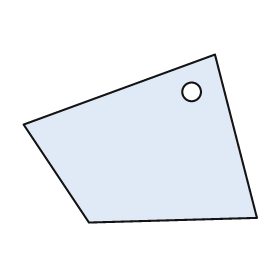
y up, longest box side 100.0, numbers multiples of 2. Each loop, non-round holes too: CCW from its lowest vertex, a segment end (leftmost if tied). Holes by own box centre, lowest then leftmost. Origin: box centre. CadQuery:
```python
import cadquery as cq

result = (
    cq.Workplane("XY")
    .moveTo(-22.0, -36.0)
    .lineTo(50.0, -34.0)
    .lineTo(32.0, 36.0)
    .lineTo(-50.0, 6.0)
    .close()
    .moveTo(22.0, 20.0)
    .circle(4.0)
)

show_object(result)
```